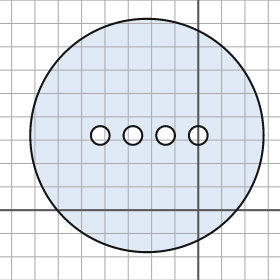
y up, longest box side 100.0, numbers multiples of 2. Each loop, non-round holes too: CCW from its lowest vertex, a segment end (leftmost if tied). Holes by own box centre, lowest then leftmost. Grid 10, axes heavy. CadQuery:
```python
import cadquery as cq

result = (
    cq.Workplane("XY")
    .moveTo(-22.0, 32.0)
    .circle(50.0)
    .moveTo(-42.0, 32.0)
    .circle(4.0)
    .moveTo(-28.0, 32.0)
    .circle(4.0)
    .moveTo(-14.0, 32.0)
    .circle(4.0)
    .moveTo(0.0, 32.0)
    .circle(4.0)
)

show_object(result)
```